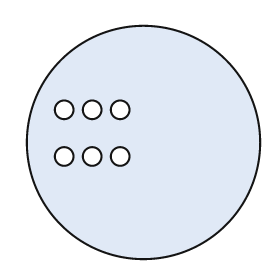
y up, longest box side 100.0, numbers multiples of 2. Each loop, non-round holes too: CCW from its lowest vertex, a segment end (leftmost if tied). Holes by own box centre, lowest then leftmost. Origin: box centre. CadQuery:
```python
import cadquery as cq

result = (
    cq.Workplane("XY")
    .moveTo(0.0, 0.0)
    .circle(50.0)
    .moveTo(-34.0, -6.0)
    .circle(4.0)
    .moveTo(-22.0, -6.0)
    .circle(4.0)
    .moveTo(-10.0, -6.0)
    .circle(4.0)
    .moveTo(-34.0, 14.0)
    .circle(4.0)
    .moveTo(-22.0, 14.0)
    .circle(4.0)
    .moveTo(-10.0, 14.0)
    .circle(4.0)
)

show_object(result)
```